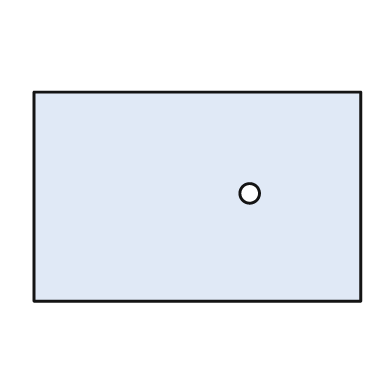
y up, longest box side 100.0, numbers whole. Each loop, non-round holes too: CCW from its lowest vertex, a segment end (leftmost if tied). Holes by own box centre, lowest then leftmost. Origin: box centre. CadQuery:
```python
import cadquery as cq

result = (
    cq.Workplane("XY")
    .moveTo(-50.0, -32.0)
    .lineTo(50.0, -32.0)
    .lineTo(50.0, 32.0)
    .lineTo(-50.0, 32.0)
    .close()
    .moveTo(16.0, 1.0)
    .circle(3.0)
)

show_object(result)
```